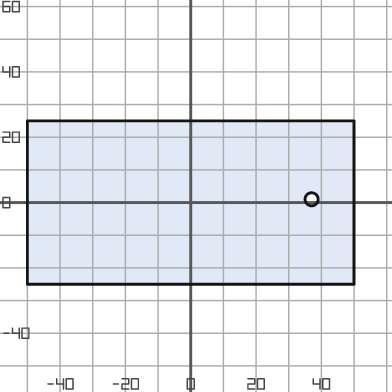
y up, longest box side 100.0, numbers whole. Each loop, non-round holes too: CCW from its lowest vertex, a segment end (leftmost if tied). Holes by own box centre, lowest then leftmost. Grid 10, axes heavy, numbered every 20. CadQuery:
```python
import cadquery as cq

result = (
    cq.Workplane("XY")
    .moveTo(-50.0, -25.0)
    .lineTo(50.0, -25.0)
    .lineTo(50.0, 25.0)
    .lineTo(-50.0, 25.0)
    .close()
    .moveTo(37.0, 1.0)
    .circle(2.0)
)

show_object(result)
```